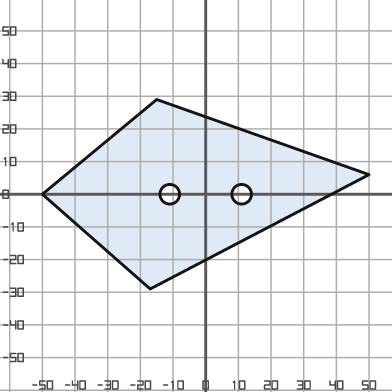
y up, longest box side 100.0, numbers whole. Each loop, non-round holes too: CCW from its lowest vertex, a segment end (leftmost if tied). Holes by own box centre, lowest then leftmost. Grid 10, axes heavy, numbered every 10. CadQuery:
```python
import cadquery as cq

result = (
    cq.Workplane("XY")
    .moveTo(-17.0, -29.0)
    .lineTo(50.0, 6.0)
    .lineTo(-15.0, 29.0)
    .lineTo(-50.0, 0.0)
    .close()
    .moveTo(-11.0, 0.0)
    .circle(3.0)
    .moveTo(11.0, 0.0)
    .circle(3.0)
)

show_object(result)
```